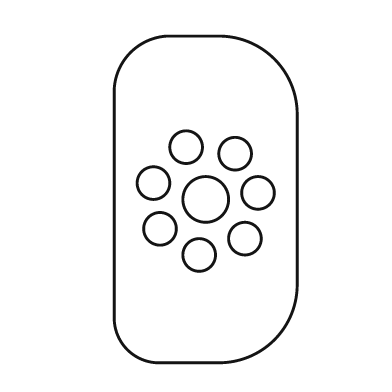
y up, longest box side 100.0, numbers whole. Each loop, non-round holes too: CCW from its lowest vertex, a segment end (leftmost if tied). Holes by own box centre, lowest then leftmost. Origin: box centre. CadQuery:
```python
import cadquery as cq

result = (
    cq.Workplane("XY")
    .moveTo(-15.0, -50.0)
    .lineTo(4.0, -50.0)
    .threePointArc((21.0, -43.0), (28.0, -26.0))
    .lineTo(28.0, 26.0)
    .threePointArc((21.0, 43.0), (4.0, 50.0))
    .lineTo(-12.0, 50.0)
    .threePointArc((-23.0, 45.0), (-28.0, 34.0))
    .lineTo(-28.0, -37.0)
    .threePointArc((-24.0, -46.0), (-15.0, -50.0))
    .close()
    .moveTo(-2.0, -17.0)
    .circle(5.0)
    .moveTo(12.0, -12.0)
    .circle(5.0)
    .moveTo(-14.0, -9.0)
    .circle(5.0)
    .moveTo(0.0, 0.0)
    .circle(7.0)
    .moveTo(16.0, 2.0)
    .circle(5.0)
    .moveTo(-16.0, 5.0)
    .circle(5.0)
    .moveTo(9.0, 14.0)
    .circle(5.0)
    .moveTo(-6.0, 16.0)
    .circle(5.0)
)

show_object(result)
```